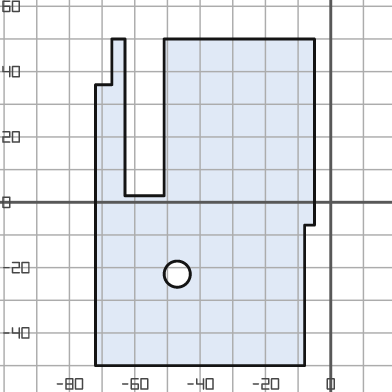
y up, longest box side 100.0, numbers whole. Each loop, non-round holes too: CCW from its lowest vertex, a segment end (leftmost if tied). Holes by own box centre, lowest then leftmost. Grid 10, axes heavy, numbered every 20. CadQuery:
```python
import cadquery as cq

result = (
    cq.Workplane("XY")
    .moveTo(-72.0, -50.0)
    .lineTo(-8.0, -50.0)
    .lineTo(-8.0, -7.0)
    .lineTo(-5.0, -7.0)
    .lineTo(-5.0, 50.0)
    .lineTo(-51.0, 50.0)
    .lineTo(-51.0, 2.0)
    .lineTo(-63.0, 2.0)
    .lineTo(-63.0, 50.0)
    .lineTo(-67.0, 50.0)
    .lineTo(-67.0, 36.0)
    .lineTo(-72.0, 36.0)
    .close()
    .moveTo(-47.0, -22.0)
    .circle(4.0)
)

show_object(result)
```